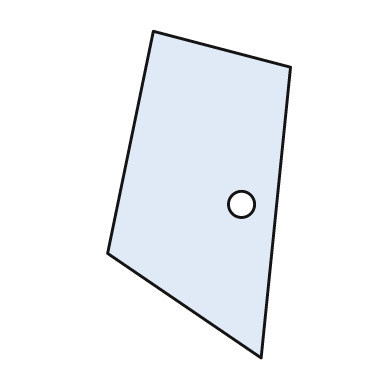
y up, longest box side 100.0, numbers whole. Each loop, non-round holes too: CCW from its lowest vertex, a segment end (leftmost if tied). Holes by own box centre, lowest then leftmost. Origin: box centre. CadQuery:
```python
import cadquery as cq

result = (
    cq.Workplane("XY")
    .moveTo(19.0, -50.0)
    .lineTo(28.0, 39.0)
    .lineTo(-14.0, 50.0)
    .lineTo(-28.0, -18.0)
    .close()
    .moveTo(13.0, -3.0)
    .circle(4.0)
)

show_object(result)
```